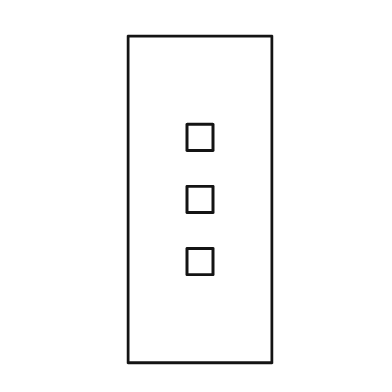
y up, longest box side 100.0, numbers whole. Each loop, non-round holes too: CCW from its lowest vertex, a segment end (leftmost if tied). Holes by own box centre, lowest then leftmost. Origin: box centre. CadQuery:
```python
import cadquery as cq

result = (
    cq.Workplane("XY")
    .moveTo(-22.0, -50.0)
    .lineTo(22.0, -50.0)
    .lineTo(22.0, 50.0)
    .lineTo(-22.0, 50.0)
    .close()
    .moveTo(-4.0, -23.0)
    .lineTo(4.0, -23.0)
    .lineTo(4.0, -15.0)
    .lineTo(-4.0, -15.0)
    .close()
    .moveTo(-4.0, -4.0)
    .lineTo(4.0, -4.0)
    .lineTo(4.0, 4.0)
    .lineTo(-4.0, 4.0)
    .close()
    .moveTo(-4.0, 15.0)
    .lineTo(4.0, 15.0)
    .lineTo(4.0, 23.0)
    .lineTo(-4.0, 23.0)
    .close()
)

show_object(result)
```